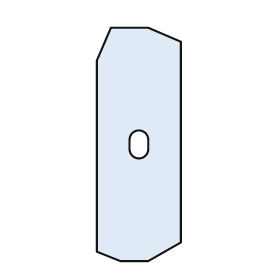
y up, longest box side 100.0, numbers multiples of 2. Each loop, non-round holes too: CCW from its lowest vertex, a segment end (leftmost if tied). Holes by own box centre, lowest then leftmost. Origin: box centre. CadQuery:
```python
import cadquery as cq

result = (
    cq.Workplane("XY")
    .moveTo(-8.0, -50.0)
    .lineTo(4.0, -50.0)
    .lineTo(18.0, -42.0)
    .lineTo(18.0, 44.0)
    .lineTo(4.0, 50.0)
    .lineTo(-12.0, 50.0)
    .lineTo(-18.0, 36.0)
    .lineTo(-18.0, -46.0)
    .close()
    .moveTo(-4.0, -2.0)
    .threePointArc((0.0, -6.0), (4.0, -2.0))
    .lineTo(4.0, 2.0)
    .threePointArc((0.0, 6.0), (-4.0, 2.0))
    .close()
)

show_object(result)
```